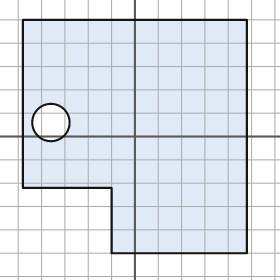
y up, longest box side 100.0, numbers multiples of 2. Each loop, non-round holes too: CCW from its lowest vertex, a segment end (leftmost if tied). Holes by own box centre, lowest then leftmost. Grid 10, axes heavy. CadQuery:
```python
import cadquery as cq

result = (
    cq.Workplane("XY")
    .moveTo(-10.0, -50.0)
    .lineTo(48.0, -50.0)
    .lineTo(48.0, 50.0)
    .lineTo(-48.0, 50.0)
    .lineTo(-48.0, -22.0)
    .lineTo(-10.0, -22.0)
    .close()
    .moveTo(-36.0, 6.0)
    .circle(8.0)
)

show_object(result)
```